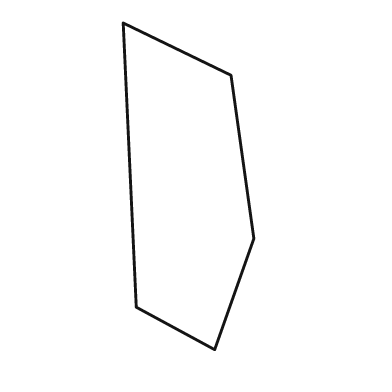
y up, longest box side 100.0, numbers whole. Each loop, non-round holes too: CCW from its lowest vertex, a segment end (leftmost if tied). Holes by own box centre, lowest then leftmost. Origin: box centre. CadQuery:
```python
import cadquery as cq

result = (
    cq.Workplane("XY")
    .moveTo(8.0, -50.0)
    .lineTo(20.0, -16.0)
    .lineTo(13.0, 34.0)
    .lineTo(-20.0, 50.0)
    .lineTo(-16.0, -37.0)
    .close()
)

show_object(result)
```